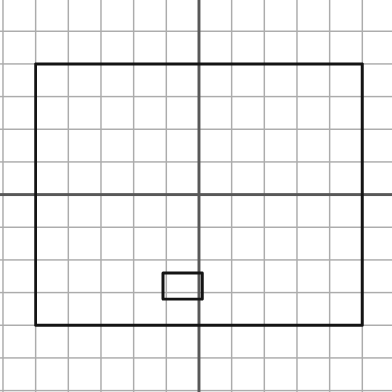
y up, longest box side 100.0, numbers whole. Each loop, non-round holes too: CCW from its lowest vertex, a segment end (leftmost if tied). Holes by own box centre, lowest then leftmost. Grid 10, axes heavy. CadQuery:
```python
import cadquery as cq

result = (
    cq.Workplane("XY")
    .moveTo(-50.0, -40.0)
    .lineTo(50.0, -40.0)
    .lineTo(50.0, 40.0)
    .lineTo(-50.0, 40.0)
    .close()
    .moveTo(-11.0, -32.0)
    .lineTo(1.0, -32.0)
    .lineTo(1.0, -24.0)
    .lineTo(-11.0, -24.0)
    .close()
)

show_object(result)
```